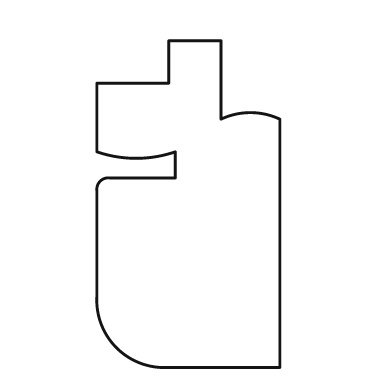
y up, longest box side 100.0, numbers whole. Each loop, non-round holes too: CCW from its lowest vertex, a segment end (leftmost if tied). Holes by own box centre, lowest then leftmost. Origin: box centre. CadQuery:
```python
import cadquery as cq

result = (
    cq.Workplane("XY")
    .moveTo(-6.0, -50.0)
    .lineTo(28.0, -50.0)
    .lineTo(28.0, 26.0)
    .threePointArc((19.0, 28.0), (10.0, 26.0))
    .lineTo(10.0, 50.0)
    .lineTo(-6.0, 50.0)
    .lineTo(-6.0, 37.0)
    .lineTo(-28.0, 37.0)
    .lineTo(-28.0, 16.0)
    .threePointArc((-16.0, 14.0), (-4.0, 16.0))
    .lineTo(-4.0, 8.0)
    .lineTo(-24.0, 8.0)
    .threePointArc((-27.0, 7.0), (-28.0, 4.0))
    .lineTo(-28.0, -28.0)
    .threePointArc((-22.0, -44.0), (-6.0, -50.0))
    .close()
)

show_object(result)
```